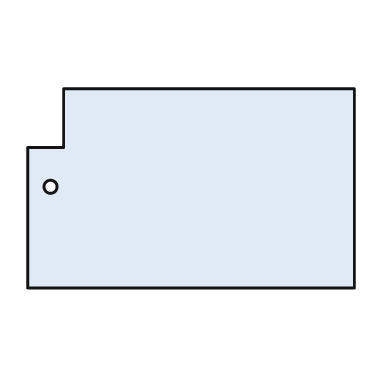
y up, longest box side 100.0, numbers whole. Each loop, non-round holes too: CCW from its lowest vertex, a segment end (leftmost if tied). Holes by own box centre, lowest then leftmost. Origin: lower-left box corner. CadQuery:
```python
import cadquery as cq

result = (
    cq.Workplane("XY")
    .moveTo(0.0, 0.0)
    .lineTo(100.0, 0.0)
    .lineTo(100.0, 61.0)
    .lineTo(11.0, 61.0)
    .lineTo(11.0, 43.0)
    .lineTo(0.0, 43.0)
    .close()
    .moveTo(7.0, 31.0)
    .circle(2.0)
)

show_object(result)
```